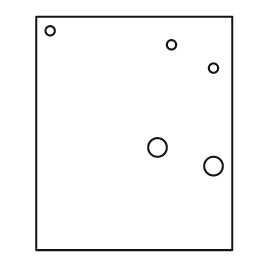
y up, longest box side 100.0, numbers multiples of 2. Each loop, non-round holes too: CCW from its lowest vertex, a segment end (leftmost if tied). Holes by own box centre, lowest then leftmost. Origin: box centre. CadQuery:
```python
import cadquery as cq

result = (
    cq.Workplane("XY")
    .moveTo(-42.0, -50.0)
    .lineTo(42.0, -50.0)
    .lineTo(42.0, 50.0)
    .lineTo(-42.0, 50.0)
    .close()
    .moveTo(34.0, -14.0)
    .circle(4.0)
    .moveTo(10.0, -6.0)
    .circle(4.0)
    .moveTo(34.0, 28.0)
    .circle(2.0)
    .moveTo(16.0, 38.0)
    .circle(2.0)
    .moveTo(-36.0, 44.0)
    .circle(2.0)
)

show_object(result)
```